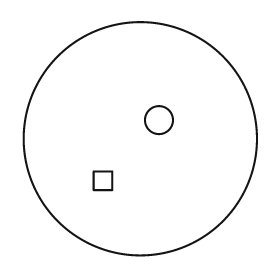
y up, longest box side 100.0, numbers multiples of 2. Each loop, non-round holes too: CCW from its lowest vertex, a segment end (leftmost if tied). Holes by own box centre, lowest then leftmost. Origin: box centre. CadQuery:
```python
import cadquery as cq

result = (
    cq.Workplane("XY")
    .moveTo(0.0, 0.0)
    .circle(50.0)
    .moveTo(-20.0, -22.0)
    .lineTo(-12.0, -22.0)
    .lineTo(-12.0, -14.0)
    .lineTo(-20.0, -14.0)
    .close()
    .moveTo(8.0, 8.0)
    .circle(6.0)
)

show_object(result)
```